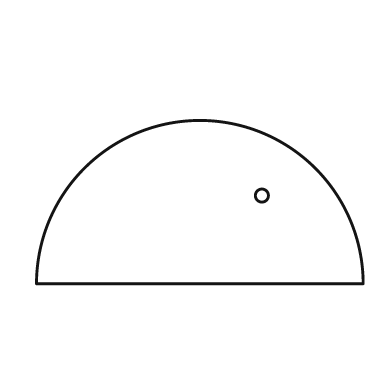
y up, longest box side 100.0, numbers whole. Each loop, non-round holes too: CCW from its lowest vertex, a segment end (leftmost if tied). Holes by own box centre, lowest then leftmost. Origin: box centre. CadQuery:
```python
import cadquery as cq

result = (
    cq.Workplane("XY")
    .moveTo(-50.0, -25.0)
    .lineTo(50.0, -25.0)
    .threePointArc((0.0, 25.0), (-50.0, -25.0))
    .close()
    .moveTo(19.0, 2.0)
    .circle(2.0)
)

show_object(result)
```